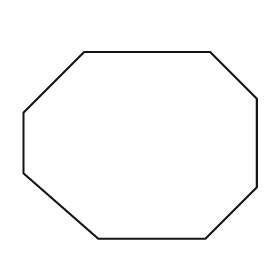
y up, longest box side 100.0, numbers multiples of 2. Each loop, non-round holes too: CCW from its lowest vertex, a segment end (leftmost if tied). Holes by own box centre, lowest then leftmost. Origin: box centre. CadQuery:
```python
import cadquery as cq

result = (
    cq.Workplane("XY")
    .moveTo(-18.0, -40.0)
    .lineTo(28.0, -40.0)
    .lineTo(50.0, -18.0)
    .lineTo(50.0, 20.0)
    .lineTo(30.0, 40.0)
    .lineTo(-24.0, 40.0)
    .lineTo(-50.0, 14.0)
    .lineTo(-50.0, -12.0)
    .close()
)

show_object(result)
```